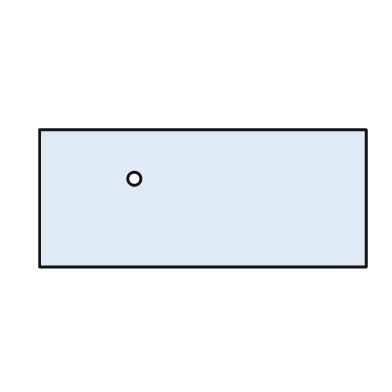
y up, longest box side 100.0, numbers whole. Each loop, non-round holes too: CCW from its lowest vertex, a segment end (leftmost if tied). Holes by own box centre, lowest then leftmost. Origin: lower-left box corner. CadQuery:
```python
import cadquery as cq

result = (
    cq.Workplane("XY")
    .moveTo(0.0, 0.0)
    .lineTo(100.0, 0.0)
    .lineTo(100.0, 42.0)
    .lineTo(0.0, 42.0)
    .close()
    .moveTo(29.0, 27.0)
    .circle(2.0)
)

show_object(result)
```